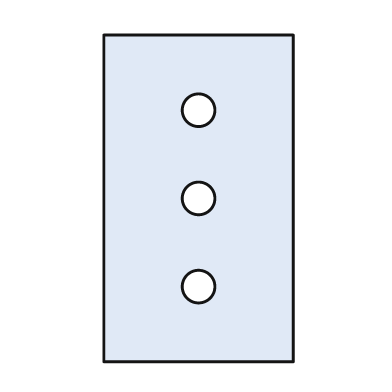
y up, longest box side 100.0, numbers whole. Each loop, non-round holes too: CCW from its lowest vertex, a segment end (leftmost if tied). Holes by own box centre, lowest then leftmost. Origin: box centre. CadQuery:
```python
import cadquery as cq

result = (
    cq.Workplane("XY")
    .moveTo(-29.0, -50.0)
    .lineTo(29.0, -50.0)
    .lineTo(29.0, 50.0)
    .lineTo(-29.0, 50.0)
    .close()
    .moveTo(0.0, -27.0)
    .circle(5.0)
    .moveTo(0.0, 0.0)
    .circle(5.0)
    .moveTo(0.0, 27.0)
    .circle(5.0)
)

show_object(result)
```